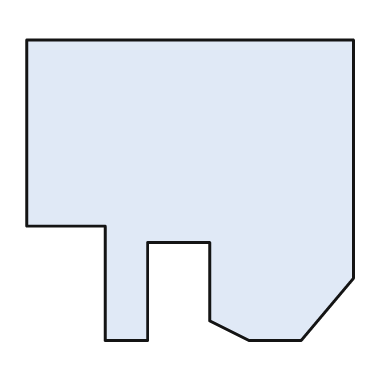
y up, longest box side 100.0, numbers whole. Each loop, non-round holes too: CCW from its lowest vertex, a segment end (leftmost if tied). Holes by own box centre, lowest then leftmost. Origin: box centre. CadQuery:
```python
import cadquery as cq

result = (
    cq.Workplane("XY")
    .moveTo(-26.0, -46.0)
    .lineTo(-13.0, -46.0)
    .lineTo(-13.0, -16.0)
    .lineTo(6.0, -16.0)
    .lineTo(6.0, -40.0)
    .lineTo(18.0, -46.0)
    .lineTo(34.0, -46.0)
    .lineTo(50.0, -27.0)
    .lineTo(50.0, 46.0)
    .lineTo(-50.0, 46.0)
    .lineTo(-50.0, -11.0)
    .lineTo(-26.0, -11.0)
    .close()
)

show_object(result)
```